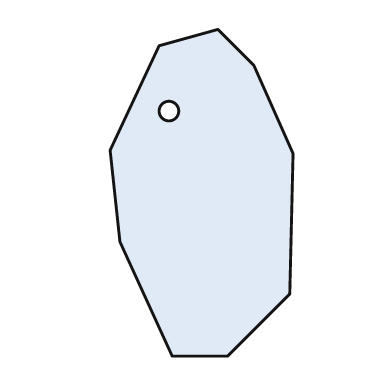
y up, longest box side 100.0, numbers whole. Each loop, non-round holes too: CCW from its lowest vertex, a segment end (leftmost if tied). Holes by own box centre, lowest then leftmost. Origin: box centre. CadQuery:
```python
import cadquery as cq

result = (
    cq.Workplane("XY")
    .moveTo(-9.0, -50.0)
    .lineTo(8.0, -50.0)
    .lineTo(27.0, -31.0)
    .lineTo(28.0, 12.0)
    .lineTo(16.0, 39.0)
    .lineTo(5.0, 50.0)
    .lineTo(-13.0, 45.0)
    .lineTo(-28.0, 13.0)
    .lineTo(-25.0, -15.0)
    .close()
    .moveTo(-10.0, 25.0)
    .circle(3.0)
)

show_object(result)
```